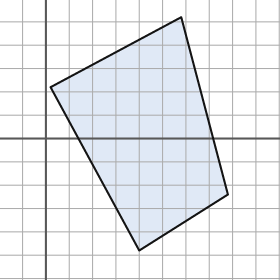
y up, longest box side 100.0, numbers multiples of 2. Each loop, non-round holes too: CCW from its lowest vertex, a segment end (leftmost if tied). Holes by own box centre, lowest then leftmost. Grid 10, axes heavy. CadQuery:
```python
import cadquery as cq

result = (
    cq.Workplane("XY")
    .moveTo(40.0, -48.0)
    .lineTo(78.0, -24.0)
    .lineTo(58.0, 52.0)
    .lineTo(2.0, 22.0)
    .close()
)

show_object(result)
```